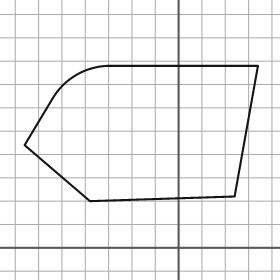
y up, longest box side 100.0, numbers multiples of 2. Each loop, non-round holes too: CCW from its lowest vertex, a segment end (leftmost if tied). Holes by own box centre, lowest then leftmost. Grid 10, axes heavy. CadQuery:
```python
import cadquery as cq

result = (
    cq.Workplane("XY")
    .moveTo(-38.0, 20.0)
    .lineTo(24.0, 22.0)
    .lineTo(34.0, 78.0)
    .lineTo(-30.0, 78.0)
    .threePointArc((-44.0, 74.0), (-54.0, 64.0))
    .lineTo(-66.0, 44.0)
    .close()
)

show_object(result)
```